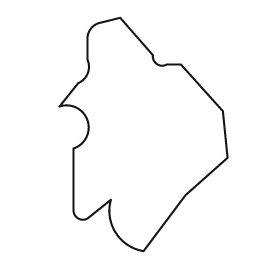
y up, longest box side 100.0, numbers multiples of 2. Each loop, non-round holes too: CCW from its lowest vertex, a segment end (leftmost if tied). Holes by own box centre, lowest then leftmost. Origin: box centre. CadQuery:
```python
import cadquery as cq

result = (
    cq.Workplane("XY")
    .moveTo(0.0, -50.0)
    .lineTo(18.0, -26.0)
    .lineTo(36.0, -10.0)
    .lineTo(34.0, 10.0)
    .lineTo(16.0, 30.0)
    .lineTo(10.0, 30.0)
    .threePointArc((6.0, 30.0), (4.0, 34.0))
    .lineTo(-10.0, 50.0)
    .lineTo(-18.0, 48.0)
    .threePointArc((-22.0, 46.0), (-24.0, 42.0))
    .lineTo(-24.0, 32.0)
    .threePointArc((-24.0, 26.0), (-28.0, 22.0))
    .lineTo(-36.0, 12.0)
    .threePointArc((-24.0, 6.0), (-30.0, -6.0))
    .lineTo(-30.0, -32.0)
    .threePointArc((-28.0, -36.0), (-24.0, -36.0))
    .lineTo(-14.0, -28.0)
    .threePointArc((-12.0, -42.0), (0.0, -50.0))
    .close()
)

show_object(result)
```